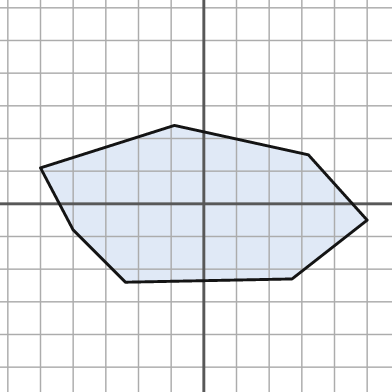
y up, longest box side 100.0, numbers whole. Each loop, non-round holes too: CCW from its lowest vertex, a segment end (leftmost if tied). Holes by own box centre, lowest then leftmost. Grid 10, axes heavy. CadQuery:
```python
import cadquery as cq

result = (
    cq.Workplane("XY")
    .moveTo(-24.0, -24.0)
    .lineTo(27.0, -23.0)
    .lineTo(50.0, -5.0)
    .lineTo(32.0, 15.0)
    .lineTo(-9.0, 24.0)
    .lineTo(-50.0, 11.0)
    .lineTo(-40.0, -8.0)
    .close()
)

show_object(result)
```